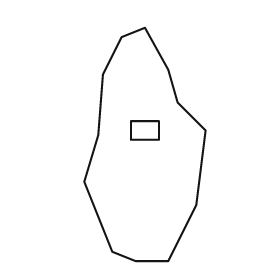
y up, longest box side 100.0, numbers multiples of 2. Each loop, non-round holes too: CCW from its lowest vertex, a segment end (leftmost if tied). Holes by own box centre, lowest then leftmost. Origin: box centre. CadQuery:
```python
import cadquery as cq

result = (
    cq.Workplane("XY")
    .moveTo(-4.0, -50.0)
    .lineTo(10.0, -50.0)
    .lineTo(22.0, -26.0)
    .lineTo(26.0, 6.0)
    .lineTo(14.0, 18.0)
    .lineTo(10.0, 32.0)
    .lineTo(0.0, 50.0)
    .lineTo(-10.0, 46.0)
    .lineTo(-18.0, 30.0)
    .lineTo(-20.0, 4.0)
    .lineTo(-26.0, -16.0)
    .lineTo(-14.0, -46.0)
    .close()
    .moveTo(-6.0, 2.0)
    .lineTo(6.0, 2.0)
    .lineTo(6.0, 10.0)
    .lineTo(-6.0, 10.0)
    .close()
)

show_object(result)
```